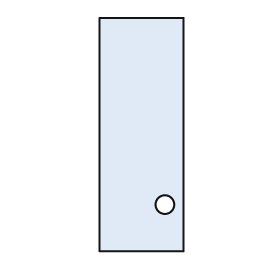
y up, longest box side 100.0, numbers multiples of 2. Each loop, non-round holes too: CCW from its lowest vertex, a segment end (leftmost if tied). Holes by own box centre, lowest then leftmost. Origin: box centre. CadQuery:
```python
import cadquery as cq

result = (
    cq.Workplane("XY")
    .moveTo(-18.0, -50.0)
    .lineTo(18.0, -50.0)
    .lineTo(18.0, 50.0)
    .lineTo(-18.0, 50.0)
    .close()
    .moveTo(10.0, -30.0)
    .circle(4.0)
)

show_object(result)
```